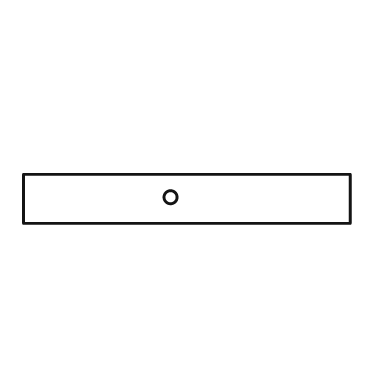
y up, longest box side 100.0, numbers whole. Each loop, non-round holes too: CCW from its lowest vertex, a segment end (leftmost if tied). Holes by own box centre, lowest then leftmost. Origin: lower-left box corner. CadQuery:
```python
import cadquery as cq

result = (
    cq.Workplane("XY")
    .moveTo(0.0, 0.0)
    .lineTo(100.0, 0.0)
    .lineTo(100.0, 15.0)
    .lineTo(0.0, 15.0)
    .close()
    .moveTo(45.0, 8.0)
    .circle(2.0)
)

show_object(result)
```